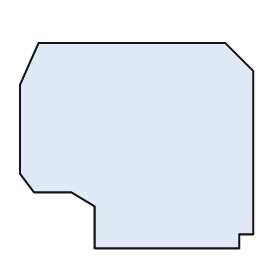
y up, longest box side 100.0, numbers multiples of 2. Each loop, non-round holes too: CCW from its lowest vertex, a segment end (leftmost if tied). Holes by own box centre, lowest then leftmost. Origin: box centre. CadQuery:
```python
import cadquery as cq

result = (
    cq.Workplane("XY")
    .moveTo(-18.0, -44.0)
    .lineTo(44.0, -44.0)
    .lineTo(44.0, -38.0)
    .lineTo(50.0, -38.0)
    .lineTo(50.0, 32.0)
    .lineTo(38.0, 44.0)
    .lineTo(-42.0, 44.0)
    .lineTo(-50.0, 26.0)
    .lineTo(-50.0, -12.0)
    .lineTo(-44.0, -20.0)
    .lineTo(-28.0, -20.0)
    .lineTo(-18.0, -26.0)
    .close()
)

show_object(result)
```